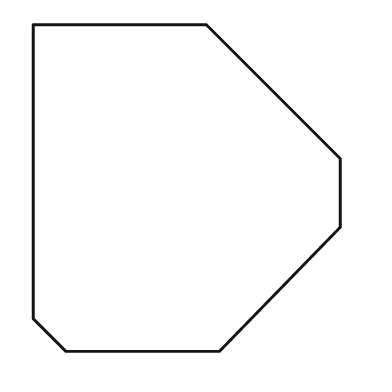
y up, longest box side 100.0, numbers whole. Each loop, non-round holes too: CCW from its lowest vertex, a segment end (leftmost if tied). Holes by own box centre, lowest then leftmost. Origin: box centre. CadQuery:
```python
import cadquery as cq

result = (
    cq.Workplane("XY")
    .moveTo(-37.0, -50.0)
    .lineTo(10.0, -50.0)
    .lineTo(47.0, -12.0)
    .lineTo(47.0, 9.0)
    .lineTo(6.0, 50.0)
    .lineTo(-47.0, 50.0)
    .lineTo(-47.0, -40.0)
    .close()
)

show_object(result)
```